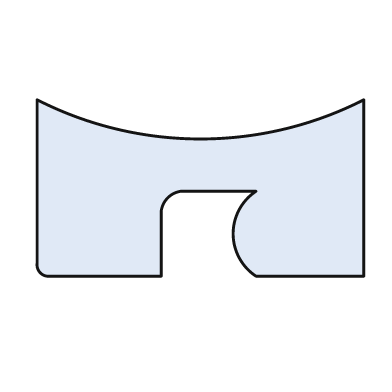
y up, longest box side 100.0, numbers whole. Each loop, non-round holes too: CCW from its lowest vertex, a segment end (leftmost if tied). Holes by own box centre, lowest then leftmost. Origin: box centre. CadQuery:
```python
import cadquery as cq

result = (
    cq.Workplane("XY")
    .moveTo(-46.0, -27.0)
    .lineTo(-12.0, -27.0)
    .lineTo(-12.0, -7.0)
    .threePointArc((-10.0, -3.0), (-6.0, -1.0))
    .lineTo(17.0, -1.0)
    .threePointArc((10.0, -14.0), (17.0, -27.0))
    .lineTo(50.0, -27.0)
    .lineTo(50.0, 27.0)
    .threePointArc((0.0, 15.0), (-50.0, 27.0))
    .lineTo(-50.0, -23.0)
    .threePointArc((-49.0, -26.0), (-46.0, -27.0))
    .close()
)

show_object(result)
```